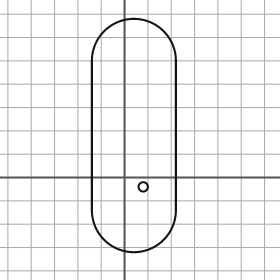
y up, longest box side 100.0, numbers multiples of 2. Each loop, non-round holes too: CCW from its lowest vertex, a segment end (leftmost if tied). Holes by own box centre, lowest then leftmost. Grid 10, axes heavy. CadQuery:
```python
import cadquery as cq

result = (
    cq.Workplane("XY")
    .moveTo(-14.0, -14.0)
    .threePointArc((4.0, -32.0), (22.0, -14.0))
    .lineTo(22.0, 50.0)
    .threePointArc((4.0, 68.0), (-14.0, 50.0))
    .close()
    .moveTo(8.0, -4.0)
    .circle(2.0)
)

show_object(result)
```